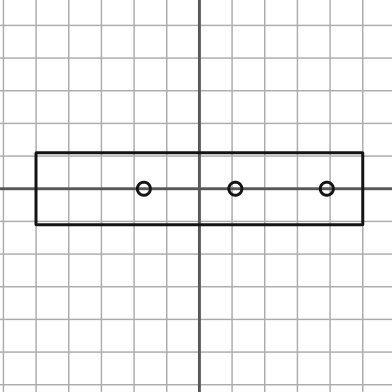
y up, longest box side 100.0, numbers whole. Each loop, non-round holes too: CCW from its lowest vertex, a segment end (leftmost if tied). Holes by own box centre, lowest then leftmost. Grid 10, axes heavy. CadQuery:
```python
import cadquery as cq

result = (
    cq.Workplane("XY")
    .moveTo(-50.0, -11.0)
    .lineTo(50.0, -11.0)
    .lineTo(50.0, 11.0)
    .lineTo(-50.0, 11.0)
    .close()
    .moveTo(-17.0, 0.0)
    .circle(2.0)
    .moveTo(11.0, 0.0)
    .circle(2.0)
    .moveTo(39.0, 0.0)
    .circle(2.0)
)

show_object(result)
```